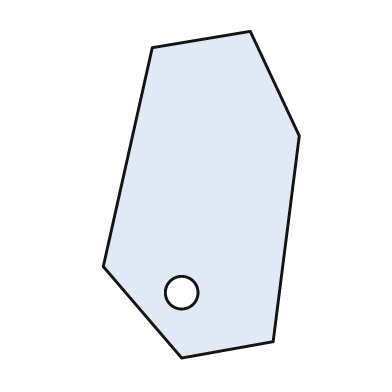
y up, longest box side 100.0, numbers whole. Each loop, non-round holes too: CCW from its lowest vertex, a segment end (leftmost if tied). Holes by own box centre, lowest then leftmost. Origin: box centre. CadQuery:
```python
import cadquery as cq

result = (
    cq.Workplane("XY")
    .moveTo(-6.0, -50.0)
    .lineTo(22.0, -45.0)
    .lineTo(30.0, 18.0)
    .lineTo(15.0, 50.0)
    .lineTo(-15.0, 45.0)
    .lineTo(-30.0, -22.0)
    .close()
    .moveTo(-6.0, -30.0)
    .circle(5.0)
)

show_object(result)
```